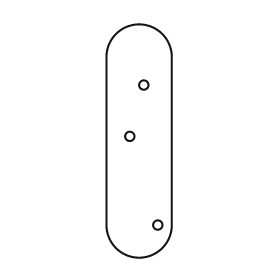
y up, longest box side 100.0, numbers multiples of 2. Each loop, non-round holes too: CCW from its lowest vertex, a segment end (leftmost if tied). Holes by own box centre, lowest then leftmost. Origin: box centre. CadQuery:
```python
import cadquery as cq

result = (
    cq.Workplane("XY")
    .moveTo(-14.0, -36.0)
    .threePointArc((0.0, -50.0), (14.0, -36.0))
    .lineTo(14.0, 36.0)
    .threePointArc((0.0, 50.0), (-14.0, 36.0))
    .close()
    .moveTo(8.0, -36.0)
    .circle(2.0)
    .moveTo(-4.0, 2.0)
    .circle(2.0)
    .moveTo(2.0, 24.0)
    .circle(2.0)
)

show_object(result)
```